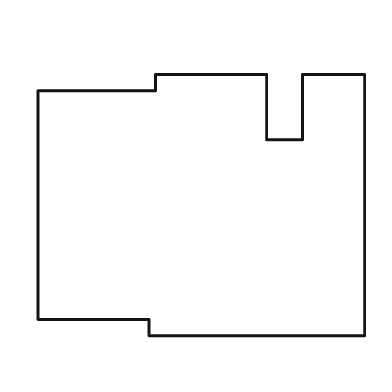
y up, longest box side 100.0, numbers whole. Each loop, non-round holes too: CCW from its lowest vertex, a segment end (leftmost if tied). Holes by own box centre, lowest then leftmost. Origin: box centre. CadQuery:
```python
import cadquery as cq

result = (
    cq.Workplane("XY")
    .moveTo(-16.0, -40.0)
    .lineTo(50.0, -40.0)
    .lineTo(50.0, 40.0)
    .lineTo(31.0, 40.0)
    .lineTo(31.0, 20.0)
    .lineTo(20.0, 20.0)
    .lineTo(20.0, 40.0)
    .lineTo(-14.0, 40.0)
    .lineTo(-14.0, 35.0)
    .lineTo(-50.0, 35.0)
    .lineTo(-50.0, -35.0)
    .lineTo(-16.0, -35.0)
    .close()
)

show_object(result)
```